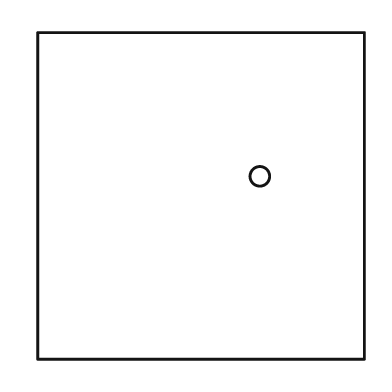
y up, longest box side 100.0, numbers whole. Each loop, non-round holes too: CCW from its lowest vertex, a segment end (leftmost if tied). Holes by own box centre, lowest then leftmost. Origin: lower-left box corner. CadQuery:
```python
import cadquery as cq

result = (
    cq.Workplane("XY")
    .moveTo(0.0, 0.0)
    .lineTo(100.0, 0.0)
    .lineTo(100.0, 100.0)
    .lineTo(0.0, 100.0)
    .close()
    .moveTo(68.0, 56.0)
    .circle(3.0)
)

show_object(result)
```